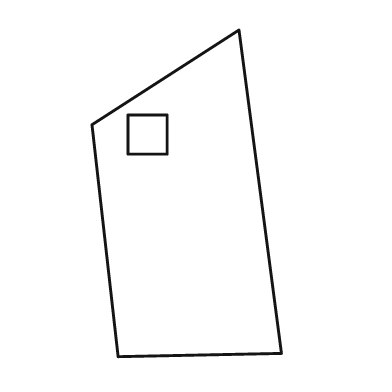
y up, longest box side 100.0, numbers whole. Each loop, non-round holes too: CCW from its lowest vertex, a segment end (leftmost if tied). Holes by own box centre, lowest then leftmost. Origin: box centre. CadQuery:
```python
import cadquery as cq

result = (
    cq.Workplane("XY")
    .moveTo(-21.0, -50.0)
    .lineTo(29.0, -49.0)
    .lineTo(16.0, 50.0)
    .lineTo(-29.0, 21.0)
    .close()
    .moveTo(-18.0, 12.0)
    .lineTo(-6.0, 12.0)
    .lineTo(-6.0, 24.0)
    .lineTo(-18.0, 24.0)
    .close()
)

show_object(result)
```